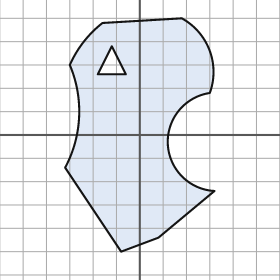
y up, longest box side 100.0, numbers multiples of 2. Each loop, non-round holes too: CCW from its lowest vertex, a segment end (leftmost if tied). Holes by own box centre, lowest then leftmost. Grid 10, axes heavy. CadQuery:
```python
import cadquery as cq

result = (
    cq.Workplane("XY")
    .moveTo(-8.0, -50.0)
    .lineTo(8.0, -44.0)
    .lineTo(32.0, -24.0)
    .threePointArc((12.0, -4.0), (30.0, 18.0))
    .threePointArc((30.0, 36.0), (18.0, 50.0))
    .lineTo(-16.0, 48.0)
    .threePointArc((-24.0, 40.0), (-30.0, 30.0))
    .threePointArc((-26.0, 8.0), (-32.0, -14.0))
    .close()
    .moveTo(-18.0, 26.0)
    .lineTo(-6.0, 26.0)
    .lineTo(-12.0, 38.0)
    .close()
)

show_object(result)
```